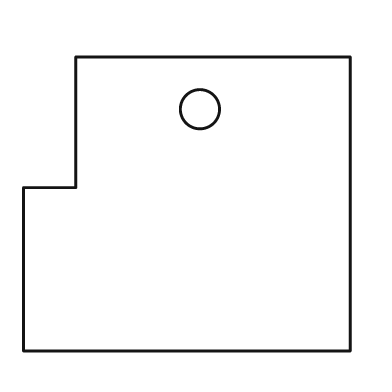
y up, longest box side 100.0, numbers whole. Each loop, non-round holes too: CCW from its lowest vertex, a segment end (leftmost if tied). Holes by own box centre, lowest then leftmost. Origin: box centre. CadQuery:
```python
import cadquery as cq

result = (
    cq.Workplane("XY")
    .moveTo(-50.0, -45.0)
    .lineTo(50.0, -45.0)
    .lineTo(50.0, 45.0)
    .lineTo(-34.0, 45.0)
    .lineTo(-34.0, 5.0)
    .lineTo(-50.0, 5.0)
    .close()
    .moveTo(4.0, 29.0)
    .circle(6.0)
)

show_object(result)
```